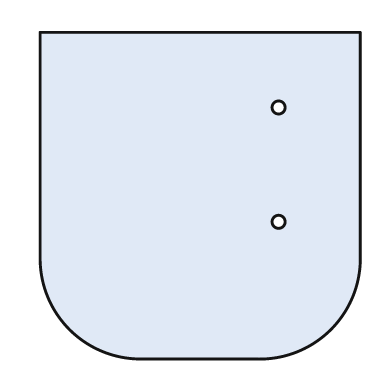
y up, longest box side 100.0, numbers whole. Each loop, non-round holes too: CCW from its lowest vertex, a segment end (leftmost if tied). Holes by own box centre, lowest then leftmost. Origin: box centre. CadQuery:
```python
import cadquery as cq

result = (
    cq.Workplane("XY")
    .moveTo(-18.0, -50.0)
    .lineTo(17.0, -50.0)
    .threePointArc((40.0, -41.0), (49.0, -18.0))
    .lineTo(49.0, 50.0)
    .lineTo(-49.0, 50.0)
    .lineTo(-49.0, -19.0)
    .threePointArc((-40.0, -41.0), (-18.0, -50.0))
    .close()
    .moveTo(24.0, -8.0)
    .circle(2.0)
    .moveTo(24.0, 27.0)
    .circle(2.0)
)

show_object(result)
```